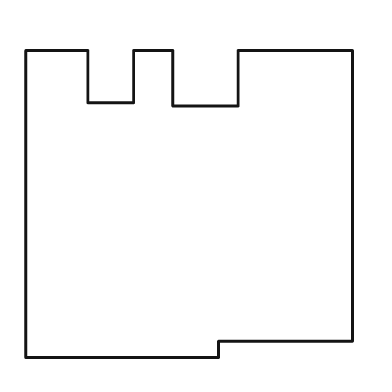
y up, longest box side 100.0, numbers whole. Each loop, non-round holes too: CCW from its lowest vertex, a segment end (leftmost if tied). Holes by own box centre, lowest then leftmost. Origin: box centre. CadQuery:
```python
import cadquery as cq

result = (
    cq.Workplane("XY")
    .moveTo(-50.0, -47.0)
    .lineTo(9.0, -47.0)
    .lineTo(9.0, -42.0)
    .lineTo(50.0, -42.0)
    .lineTo(50.0, 47.0)
    .lineTo(15.0, 47.0)
    .lineTo(15.0, 30.0)
    .lineTo(-5.0, 30.0)
    .lineTo(-5.0, 47.0)
    .lineTo(-17.0, 47.0)
    .lineTo(-17.0, 31.0)
    .lineTo(-31.0, 31.0)
    .lineTo(-31.0, 47.0)
    .lineTo(-50.0, 47.0)
    .close()
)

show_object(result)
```